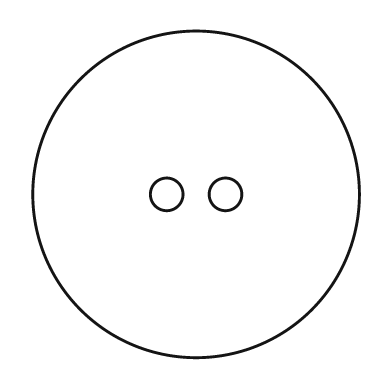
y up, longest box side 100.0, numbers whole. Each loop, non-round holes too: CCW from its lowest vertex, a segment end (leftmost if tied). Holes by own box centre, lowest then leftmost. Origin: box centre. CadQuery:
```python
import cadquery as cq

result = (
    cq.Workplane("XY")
    .moveTo(0.0, 0.0)
    .circle(50.0)
    .moveTo(-9.0, 0.0)
    .circle(5.0)
    .moveTo(9.0, 0.0)
    .circle(5.0)
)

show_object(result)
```